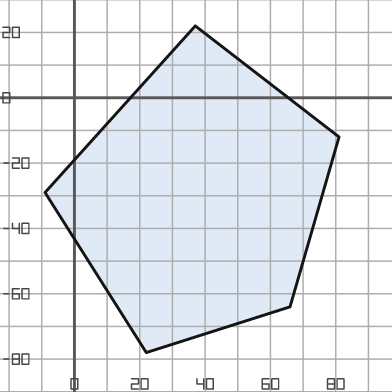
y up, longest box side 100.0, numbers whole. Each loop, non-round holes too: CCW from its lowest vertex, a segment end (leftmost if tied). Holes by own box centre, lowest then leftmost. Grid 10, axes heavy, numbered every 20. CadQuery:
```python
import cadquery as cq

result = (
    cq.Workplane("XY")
    .moveTo(22.0, -78.0)
    .lineTo(66.0, -64.0)
    .lineTo(81.0, -12.0)
    .lineTo(37.0, 22.0)
    .lineTo(-9.0, -29.0)
    .close()
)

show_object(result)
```